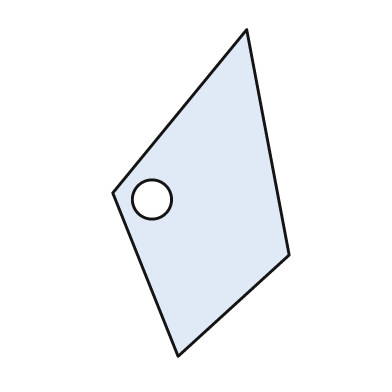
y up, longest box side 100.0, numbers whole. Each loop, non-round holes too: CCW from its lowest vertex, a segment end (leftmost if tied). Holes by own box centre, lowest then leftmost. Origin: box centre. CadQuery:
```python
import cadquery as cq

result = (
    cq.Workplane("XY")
    .moveTo(-7.0, -50.0)
    .lineTo(27.0, -19.0)
    .lineTo(14.0, 50.0)
    .lineTo(-27.0, 0.0)
    .close()
    .moveTo(-15.0, -2.0)
    .circle(6.0)
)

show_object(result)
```